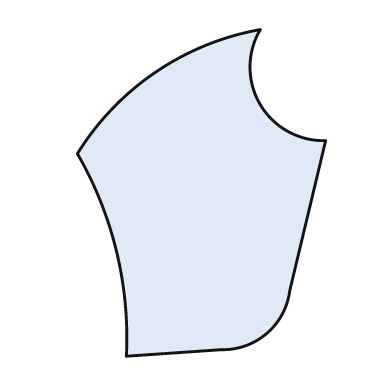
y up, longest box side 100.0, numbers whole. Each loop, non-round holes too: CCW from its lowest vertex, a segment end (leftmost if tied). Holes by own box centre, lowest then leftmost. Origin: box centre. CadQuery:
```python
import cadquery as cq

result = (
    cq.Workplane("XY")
    .moveTo(-23.0, -50.0)
    .lineTo(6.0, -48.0)
    .threePointArc((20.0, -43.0), (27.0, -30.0))
    .lineTo(38.0, 16.0)
    .threePointArc((18.0, 27.0), (18.0, 50.0))
    .threePointArc((-14.0, 37.0), (-38.0, 12.0))
    .threePointArc((-26.0, -18.0), (-23.0, -50.0))
    .close()
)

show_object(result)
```